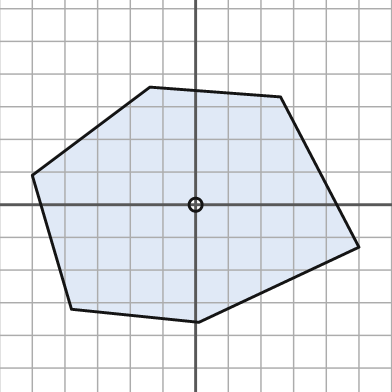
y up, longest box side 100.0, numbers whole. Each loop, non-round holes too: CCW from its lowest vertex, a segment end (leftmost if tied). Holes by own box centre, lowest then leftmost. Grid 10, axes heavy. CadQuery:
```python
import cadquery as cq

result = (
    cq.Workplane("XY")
    .moveTo(1.0, -36.0)
    .lineTo(50.0, -13.0)
    .lineTo(26.0, 33.0)
    .lineTo(-14.0, 36.0)
    .lineTo(-50.0, 9.0)
    .lineTo(-38.0, -32.0)
    .close()
    .moveTo(0.0, 0.0)
    .circle(2.0)
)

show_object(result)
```